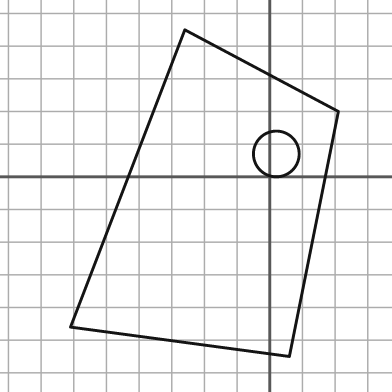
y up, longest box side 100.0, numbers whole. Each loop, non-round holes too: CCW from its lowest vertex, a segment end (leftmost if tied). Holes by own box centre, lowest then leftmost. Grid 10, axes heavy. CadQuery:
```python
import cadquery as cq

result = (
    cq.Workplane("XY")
    .moveTo(6.0, -55.0)
    .lineTo(21.0, 20.0)
    .lineTo(-26.0, 45.0)
    .lineTo(-61.0, -46.0)
    .close()
    .moveTo(2.0, 7.0)
    .circle(7.0)
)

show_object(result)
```